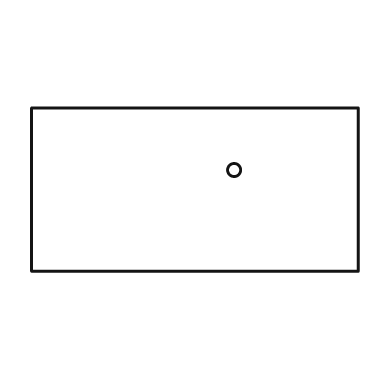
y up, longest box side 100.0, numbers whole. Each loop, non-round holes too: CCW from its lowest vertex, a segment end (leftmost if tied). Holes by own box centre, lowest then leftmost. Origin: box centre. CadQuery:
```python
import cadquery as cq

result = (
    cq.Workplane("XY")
    .moveTo(-50.0, -25.0)
    .lineTo(50.0, -25.0)
    .lineTo(50.0, 25.0)
    .lineTo(-50.0, 25.0)
    .close()
    .moveTo(12.0, 6.0)
    .circle(2.0)
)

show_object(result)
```